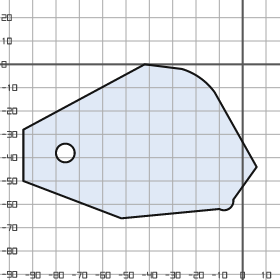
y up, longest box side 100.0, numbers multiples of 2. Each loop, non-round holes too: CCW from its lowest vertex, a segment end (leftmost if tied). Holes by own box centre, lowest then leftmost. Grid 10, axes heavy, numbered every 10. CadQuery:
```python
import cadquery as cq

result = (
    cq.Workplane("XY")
    .moveTo(-52.0, -66.0)
    .lineTo(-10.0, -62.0)
    .threePointArc((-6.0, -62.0), (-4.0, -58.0))
    .lineTo(6.0, -44.0)
    .lineTo(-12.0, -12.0)
    .threePointArc((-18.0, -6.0), (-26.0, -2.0))
    .lineTo(-42.0, 0.0)
    .lineTo(-94.0, -28.0)
    .lineTo(-94.0, -50.0)
    .close()
    .moveTo(-76.0, -38.0)
    .circle(4.0)
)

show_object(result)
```